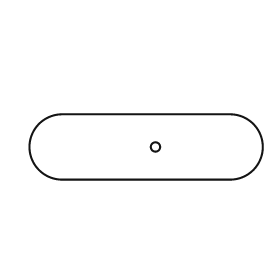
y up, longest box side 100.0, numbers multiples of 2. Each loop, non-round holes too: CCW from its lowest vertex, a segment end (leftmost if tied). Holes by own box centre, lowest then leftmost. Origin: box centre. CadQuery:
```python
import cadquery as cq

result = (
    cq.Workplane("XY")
    .moveTo(-36.0, -14.0)
    .lineTo(36.0, -14.0)
    .threePointArc((50.0, 0.0), (36.0, 14.0))
    .lineTo(-36.0, 14.0)
    .threePointArc((-50.0, 0.0), (-36.0, -14.0))
    .close()
    .moveTo(4.0, 0.0)
    .circle(2.0)
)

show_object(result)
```